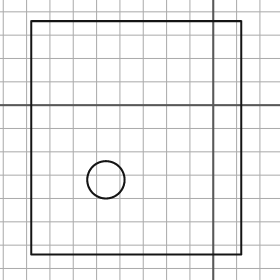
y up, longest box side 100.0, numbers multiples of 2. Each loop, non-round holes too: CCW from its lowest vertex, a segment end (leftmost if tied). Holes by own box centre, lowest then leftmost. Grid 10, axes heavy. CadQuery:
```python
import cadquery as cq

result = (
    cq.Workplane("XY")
    .moveTo(-78.0, -64.0)
    .lineTo(12.0, -64.0)
    .lineTo(12.0, 36.0)
    .lineTo(-78.0, 36.0)
    .close()
    .moveTo(-46.0, -32.0)
    .circle(8.0)
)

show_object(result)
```